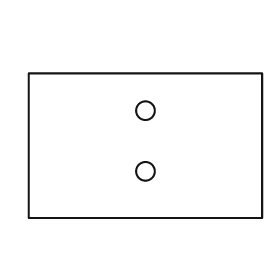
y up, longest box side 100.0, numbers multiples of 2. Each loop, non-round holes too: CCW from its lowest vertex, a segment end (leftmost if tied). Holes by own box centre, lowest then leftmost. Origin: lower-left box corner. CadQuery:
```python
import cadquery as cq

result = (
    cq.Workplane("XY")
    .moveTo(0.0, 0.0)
    .lineTo(100.0, 0.0)
    .lineTo(100.0, 62.0)
    .lineTo(0.0, 62.0)
    .close()
    .moveTo(50.0, 20.0)
    .circle(4.0)
    .moveTo(50.0, 46.0)
    .circle(4.0)
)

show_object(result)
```